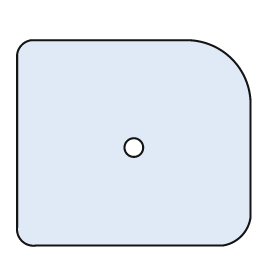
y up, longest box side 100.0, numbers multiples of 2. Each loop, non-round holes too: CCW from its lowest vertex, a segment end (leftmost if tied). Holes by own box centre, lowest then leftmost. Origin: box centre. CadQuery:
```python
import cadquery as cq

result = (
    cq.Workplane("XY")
    .moveTo(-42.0, -44.0)
    .lineTo(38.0, -44.0)
    .threePointArc((46.0, -40.0), (50.0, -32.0))
    .lineTo(50.0, 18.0)
    .threePointArc((42.0, 36.0), (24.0, 44.0))
    .lineTo(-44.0, 44.0)
    .threePointArc((-48.0, 42.0), (-50.0, 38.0))
    .lineTo(-50.0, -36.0)
    .threePointArc((-48.0, -42.0), (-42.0, -44.0))
    .close()
    .moveTo(0.0, -2.0)
    .circle(4.0)
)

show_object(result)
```